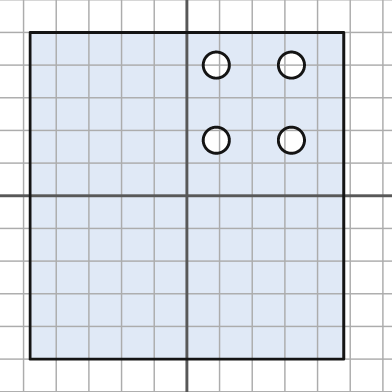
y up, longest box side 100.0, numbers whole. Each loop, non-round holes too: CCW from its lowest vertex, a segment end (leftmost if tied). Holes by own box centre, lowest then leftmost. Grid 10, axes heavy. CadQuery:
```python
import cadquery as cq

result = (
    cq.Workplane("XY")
    .moveTo(-48.0, -50.0)
    .lineTo(48.0, -50.0)
    .lineTo(48.0, 50.0)
    .lineTo(-48.0, 50.0)
    .close()
    .moveTo(9.0, 17.0)
    .circle(4.0)
    .moveTo(32.0, 17.0)
    .circle(4.0)
    .moveTo(9.0, 40.0)
    .circle(4.0)
    .moveTo(32.0, 40.0)
    .circle(4.0)
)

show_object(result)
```